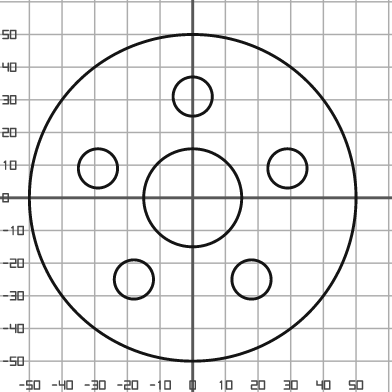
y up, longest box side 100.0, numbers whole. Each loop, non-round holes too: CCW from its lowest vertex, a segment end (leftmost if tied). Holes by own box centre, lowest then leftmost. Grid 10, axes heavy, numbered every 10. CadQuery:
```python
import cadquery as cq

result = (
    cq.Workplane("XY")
    .moveTo(0.0, 0.0)
    .circle(50.0)
    .moveTo(-18.0, -25.0)
    .circle(6.0)
    .moveTo(18.0, -25.0)
    .circle(6.0)
    .moveTo(0.0, 0.0)
    .circle(15.0)
    .moveTo(-29.0, 9.0)
    .circle(6.0)
    .moveTo(29.0, 9.0)
    .circle(6.0)
    .moveTo(0.0, 31.0)
    .circle(6.0)
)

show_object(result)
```